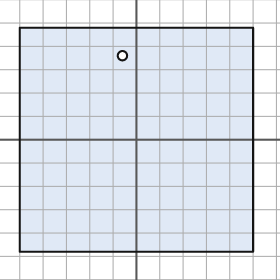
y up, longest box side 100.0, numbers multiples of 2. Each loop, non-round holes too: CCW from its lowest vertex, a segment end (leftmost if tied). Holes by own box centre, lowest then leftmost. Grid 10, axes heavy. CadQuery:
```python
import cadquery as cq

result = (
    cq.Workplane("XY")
    .moveTo(-50.0, -48.0)
    .lineTo(50.0, -48.0)
    .lineTo(50.0, 48.0)
    .lineTo(-50.0, 48.0)
    .close()
    .moveTo(-6.0, 36.0)
    .circle(2.0)
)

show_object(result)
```